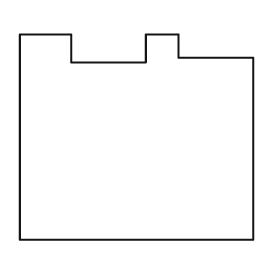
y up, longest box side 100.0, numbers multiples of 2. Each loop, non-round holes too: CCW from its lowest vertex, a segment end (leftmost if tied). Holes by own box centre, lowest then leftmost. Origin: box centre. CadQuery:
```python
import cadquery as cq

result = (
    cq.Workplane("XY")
    .moveTo(-50.0, -44.0)
    .lineTo(50.0, -44.0)
    .lineTo(50.0, 34.0)
    .lineTo(18.0, 34.0)
    .lineTo(18.0, 44.0)
    .lineTo(4.0, 44.0)
    .lineTo(4.0, 32.0)
    .lineTo(-28.0, 32.0)
    .lineTo(-28.0, 44.0)
    .lineTo(-50.0, 44.0)
    .close()
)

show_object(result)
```